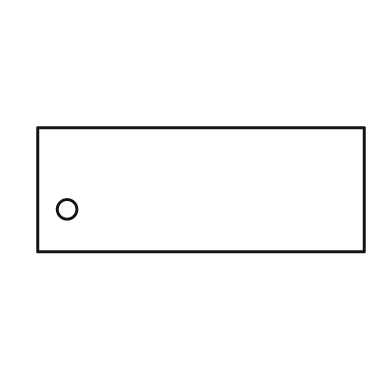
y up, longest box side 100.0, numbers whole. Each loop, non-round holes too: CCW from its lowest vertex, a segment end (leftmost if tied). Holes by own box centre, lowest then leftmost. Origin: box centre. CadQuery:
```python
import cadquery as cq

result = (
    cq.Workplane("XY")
    .moveTo(-50.0, -19.0)
    .lineTo(50.0, -19.0)
    .lineTo(50.0, 19.0)
    .lineTo(-50.0, 19.0)
    .close()
    .moveTo(-41.0, -6.0)
    .circle(3.0)
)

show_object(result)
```